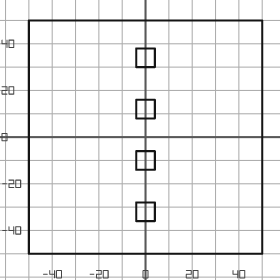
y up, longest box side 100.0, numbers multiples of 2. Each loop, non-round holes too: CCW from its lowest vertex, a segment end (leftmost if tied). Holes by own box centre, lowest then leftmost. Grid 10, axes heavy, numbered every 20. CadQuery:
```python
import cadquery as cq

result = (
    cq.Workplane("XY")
    .moveTo(-50.0, -50.0)
    .lineTo(50.0, -50.0)
    .lineTo(50.0, 50.0)
    .lineTo(-50.0, 50.0)
    .close()
    .moveTo(-4.0, -36.0)
    .lineTo(4.0, -36.0)
    .lineTo(4.0, -28.0)
    .lineTo(-4.0, -28.0)
    .close()
    .moveTo(-4.0, -14.0)
    .lineTo(4.0, -14.0)
    .lineTo(4.0, -6.0)
    .lineTo(-4.0, -6.0)
    .close()
    .moveTo(-4.0, 8.0)
    .lineTo(4.0, 8.0)
    .lineTo(4.0, 16.0)
    .lineTo(-4.0, 16.0)
    .close()
    .moveTo(-4.0, 30.0)
    .lineTo(4.0, 30.0)
    .lineTo(4.0, 38.0)
    .lineTo(-4.0, 38.0)
    .close()
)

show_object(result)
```